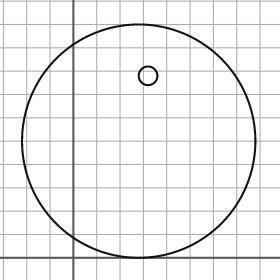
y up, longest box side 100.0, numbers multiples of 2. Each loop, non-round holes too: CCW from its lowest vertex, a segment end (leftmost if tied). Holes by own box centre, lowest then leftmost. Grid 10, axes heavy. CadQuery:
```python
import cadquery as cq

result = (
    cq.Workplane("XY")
    .moveTo(28.0, 50.0)
    .circle(50.0)
    .moveTo(32.0, 78.0)
    .circle(4.0)
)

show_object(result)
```